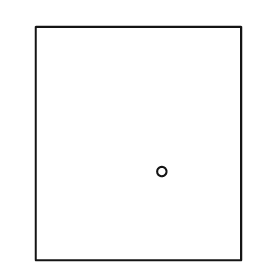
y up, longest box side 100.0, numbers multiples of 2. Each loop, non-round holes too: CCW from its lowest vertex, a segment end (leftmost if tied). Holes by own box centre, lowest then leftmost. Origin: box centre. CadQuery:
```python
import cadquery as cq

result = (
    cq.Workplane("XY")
    .moveTo(-44.0, -50.0)
    .lineTo(44.0, -50.0)
    .lineTo(44.0, 50.0)
    .lineTo(-44.0, 50.0)
    .close()
    .moveTo(10.0, -12.0)
    .circle(2.0)
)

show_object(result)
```